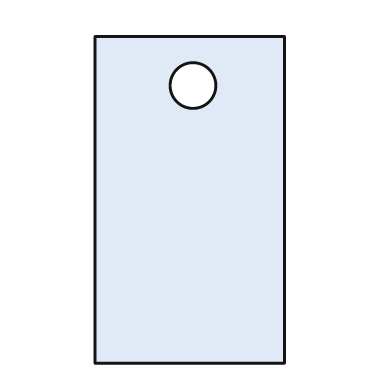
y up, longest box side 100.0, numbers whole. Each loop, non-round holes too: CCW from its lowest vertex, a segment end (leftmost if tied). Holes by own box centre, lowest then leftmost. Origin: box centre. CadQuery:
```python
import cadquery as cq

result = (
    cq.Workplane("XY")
    .moveTo(-29.0, -50.0)
    .lineTo(29.0, -50.0)
    .lineTo(29.0, 50.0)
    .lineTo(-29.0, 50.0)
    .close()
    .moveTo(1.0, 35.0)
    .circle(7.0)
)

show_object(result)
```